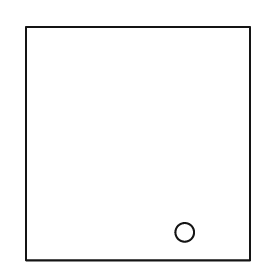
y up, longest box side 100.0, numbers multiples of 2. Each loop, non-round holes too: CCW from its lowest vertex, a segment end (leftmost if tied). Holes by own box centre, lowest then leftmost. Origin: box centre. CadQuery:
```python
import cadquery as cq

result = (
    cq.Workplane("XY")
    .moveTo(-48.0, -50.0)
    .lineTo(48.0, -50.0)
    .lineTo(48.0, 50.0)
    .lineTo(-48.0, 50.0)
    .close()
    .moveTo(20.0, -38.0)
    .circle(4.0)
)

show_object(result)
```